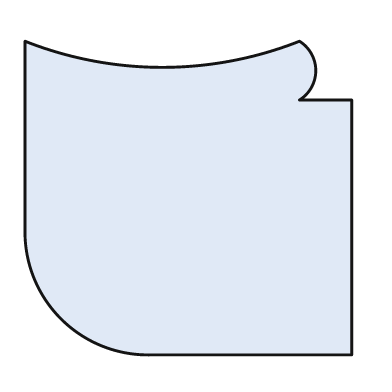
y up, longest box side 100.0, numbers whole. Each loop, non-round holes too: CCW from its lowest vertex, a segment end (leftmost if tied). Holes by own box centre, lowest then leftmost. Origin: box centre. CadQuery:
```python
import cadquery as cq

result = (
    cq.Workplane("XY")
    .moveTo(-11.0, -48.0)
    .lineTo(50.0, -48.0)
    .lineTo(50.0, 30.0)
    .lineTo(34.0, 30.0)
    .threePointArc((39.0, 39.0), (34.0, 48.0))
    .threePointArc((-8.0, 40.0), (-50.0, 48.0))
    .lineTo(-50.0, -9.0)
    .threePointArc((-39.0, -37.0), (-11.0, -48.0))
    .close()
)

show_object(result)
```